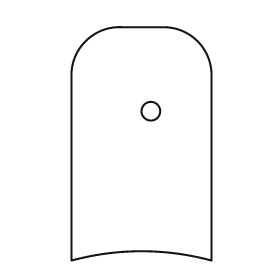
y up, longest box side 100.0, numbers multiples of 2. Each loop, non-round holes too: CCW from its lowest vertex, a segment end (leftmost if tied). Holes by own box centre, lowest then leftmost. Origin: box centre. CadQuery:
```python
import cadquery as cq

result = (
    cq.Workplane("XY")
    .moveTo(-30.0, -50.0)
    .threePointArc((0.0, -46.0), (30.0, -50.0))
    .lineTo(30.0, 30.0)
    .threePointArc((24.0, 44.0), (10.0, 50.0))
    .lineTo(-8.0, 50.0)
    .threePointArc((-24.0, 44.0), (-30.0, 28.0))
    .close()
    .moveTo(4.0, 14.0)
    .circle(4.0)
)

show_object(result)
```